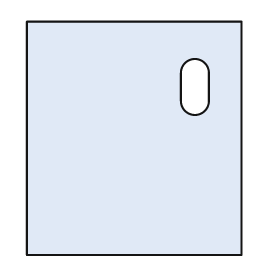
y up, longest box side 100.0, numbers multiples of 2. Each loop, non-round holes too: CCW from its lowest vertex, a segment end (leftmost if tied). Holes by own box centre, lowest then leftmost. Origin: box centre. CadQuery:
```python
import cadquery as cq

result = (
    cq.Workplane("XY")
    .moveTo(-46.0, -50.0)
    .lineTo(46.0, -50.0)
    .lineTo(46.0, 50.0)
    .lineTo(-46.0, 50.0)
    .close()
    .moveTo(20.0, 16.0)
    .threePointArc((26.0, 10.0), (32.0, 16.0))
    .lineTo(32.0, 28.0)
    .threePointArc((26.0, 34.0), (20.0, 28.0))
    .close()
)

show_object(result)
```